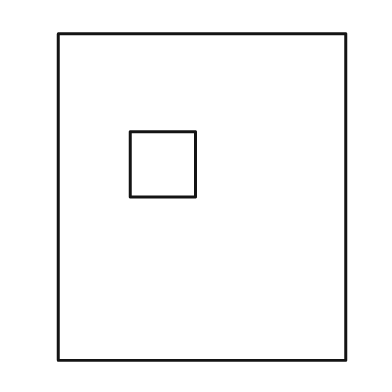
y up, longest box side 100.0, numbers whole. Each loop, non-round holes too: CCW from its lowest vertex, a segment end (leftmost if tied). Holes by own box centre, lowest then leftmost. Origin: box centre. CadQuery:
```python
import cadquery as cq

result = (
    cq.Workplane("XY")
    .moveTo(-44.0, -50.0)
    .lineTo(44.0, -50.0)
    .lineTo(44.0, 50.0)
    .lineTo(-44.0, 50.0)
    .close()
    .moveTo(-22.0, 0.0)
    .lineTo(-2.0, 0.0)
    .lineTo(-2.0, 20.0)
    .lineTo(-22.0, 20.0)
    .close()
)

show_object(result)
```